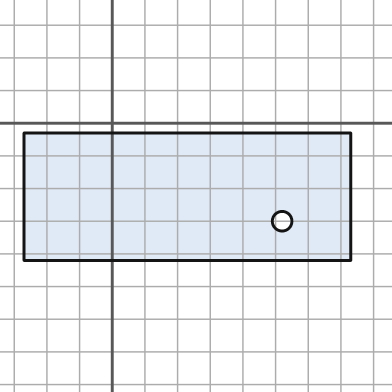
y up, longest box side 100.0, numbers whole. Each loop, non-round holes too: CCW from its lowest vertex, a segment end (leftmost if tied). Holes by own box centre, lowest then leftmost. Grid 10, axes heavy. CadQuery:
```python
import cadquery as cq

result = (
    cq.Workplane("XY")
    .moveTo(-27.0, -42.0)
    .lineTo(73.0, -42.0)
    .lineTo(73.0, -3.0)
    .lineTo(-27.0, -3.0)
    .close()
    .moveTo(52.0, -30.0)
    .circle(3.0)
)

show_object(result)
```